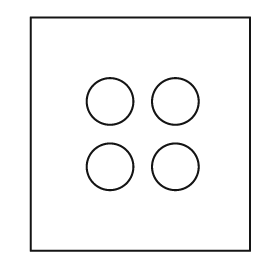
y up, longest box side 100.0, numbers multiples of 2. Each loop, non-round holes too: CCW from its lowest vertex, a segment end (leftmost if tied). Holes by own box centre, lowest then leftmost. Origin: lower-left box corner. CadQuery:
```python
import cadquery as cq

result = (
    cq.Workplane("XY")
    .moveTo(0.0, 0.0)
    .lineTo(94.0, 0.0)
    .lineTo(94.0, 100.0)
    .lineTo(0.0, 100.0)
    .close()
    .moveTo(34.0, 36.0)
    .circle(10.0)
    .moveTo(62.0, 36.0)
    .circle(10.0)
    .moveTo(34.0, 64.0)
    .circle(10.0)
    .moveTo(62.0, 64.0)
    .circle(10.0)
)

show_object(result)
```